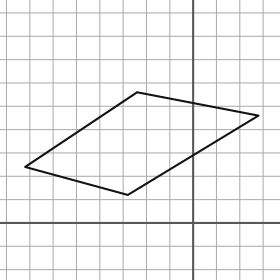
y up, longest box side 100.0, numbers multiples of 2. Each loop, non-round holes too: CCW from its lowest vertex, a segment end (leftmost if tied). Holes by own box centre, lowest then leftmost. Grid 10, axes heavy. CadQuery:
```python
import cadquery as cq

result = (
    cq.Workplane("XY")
    .moveTo(-28.0, 12.0)
    .lineTo(28.0, 46.0)
    .lineTo(-24.0, 56.0)
    .lineTo(-72.0, 24.0)
    .close()
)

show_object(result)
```